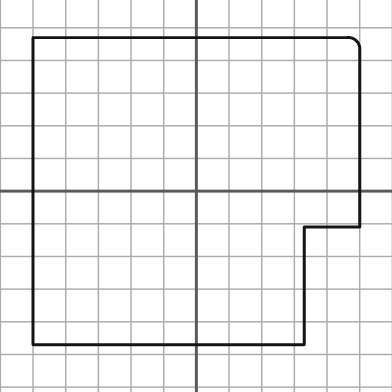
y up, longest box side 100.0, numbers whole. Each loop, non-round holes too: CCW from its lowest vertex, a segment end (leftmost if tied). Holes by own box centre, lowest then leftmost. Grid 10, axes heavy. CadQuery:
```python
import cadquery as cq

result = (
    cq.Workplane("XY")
    .moveTo(-50.0, -47.0)
    .lineTo(33.0, -47.0)
    .lineTo(33.0, -11.0)
    .lineTo(50.0, -11.0)
    .lineTo(50.0, 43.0)
    .threePointArc((49.0, 46.0), (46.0, 47.0))
    .lineTo(-50.0, 47.0)
    .close()
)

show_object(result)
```